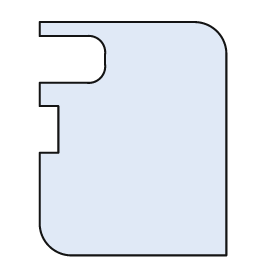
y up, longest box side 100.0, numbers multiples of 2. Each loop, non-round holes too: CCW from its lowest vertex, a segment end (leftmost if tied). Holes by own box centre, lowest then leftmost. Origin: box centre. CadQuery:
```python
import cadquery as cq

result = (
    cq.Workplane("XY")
    .moveTo(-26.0, -50.0)
    .lineTo(40.0, -50.0)
    .lineTo(40.0, 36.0)
    .threePointArc((36.0, 46.0), (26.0, 50.0))
    .lineTo(-40.0, 50.0)
    .lineTo(-40.0, 44.0)
    .lineTo(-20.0, 44.0)
    .threePointArc((-14.0, 42.0), (-12.0, 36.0))
    .lineTo(-12.0, 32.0)
    .threePointArc((-14.0, 26.0), (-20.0, 24.0))
    .lineTo(-40.0, 24.0)
    .lineTo(-40.0, 14.0)
    .lineTo(-32.0, 14.0)
    .lineTo(-32.0, -6.0)
    .lineTo(-40.0, -6.0)
    .lineTo(-40.0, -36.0)
    .threePointArc((-36.0, -46.0), (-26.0, -50.0))
    .close()
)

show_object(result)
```